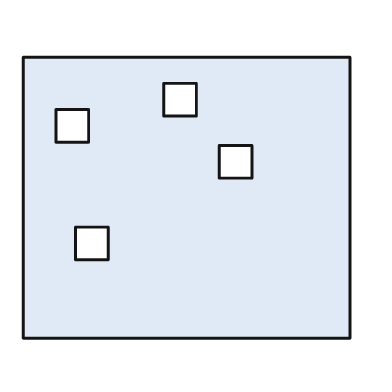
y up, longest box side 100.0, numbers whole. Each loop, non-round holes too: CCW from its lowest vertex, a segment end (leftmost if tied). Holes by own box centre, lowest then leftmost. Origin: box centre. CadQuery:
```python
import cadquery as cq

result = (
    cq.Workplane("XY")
    .moveTo(-50.0, -43.0)
    .lineTo(50.0, -43.0)
    .lineTo(50.0, 43.0)
    .lineTo(-50.0, 43.0)
    .close()
    .moveTo(-34.0, -19.0)
    .lineTo(-24.0, -19.0)
    .lineTo(-24.0, -9.0)
    .lineTo(-34.0, -9.0)
    .close()
    .moveTo(10.0, 6.0)
    .lineTo(20.0, 6.0)
    .lineTo(20.0, 16.0)
    .lineTo(10.0, 16.0)
    .close()
    .moveTo(-40.0, 17.0)
    .lineTo(-30.0, 17.0)
    .lineTo(-30.0, 27.0)
    .lineTo(-40.0, 27.0)
    .close()
    .moveTo(-7.0, 25.0)
    .lineTo(3.0, 25.0)
    .lineTo(3.0, 35.0)
    .lineTo(-7.0, 35.0)
    .close()
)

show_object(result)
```